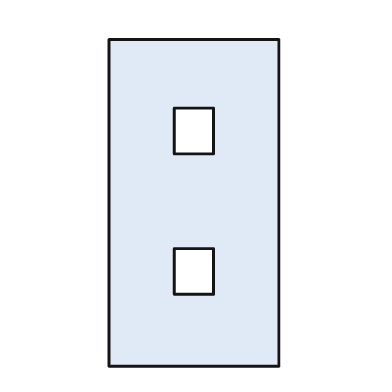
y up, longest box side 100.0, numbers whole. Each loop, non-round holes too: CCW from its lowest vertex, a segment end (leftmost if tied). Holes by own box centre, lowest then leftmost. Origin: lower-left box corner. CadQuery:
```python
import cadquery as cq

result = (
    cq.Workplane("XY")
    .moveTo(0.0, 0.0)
    .lineTo(52.0, 0.0)
    .lineTo(52.0, 100.0)
    .lineTo(0.0, 100.0)
    .close()
    .moveTo(20.0, 22.0)
    .lineTo(32.0, 22.0)
    .lineTo(32.0, 36.0)
    .lineTo(20.0, 36.0)
    .close()
    .moveTo(20.0, 65.0)
    .lineTo(32.0, 65.0)
    .lineTo(32.0, 79.0)
    .lineTo(20.0, 79.0)
    .close()
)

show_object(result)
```